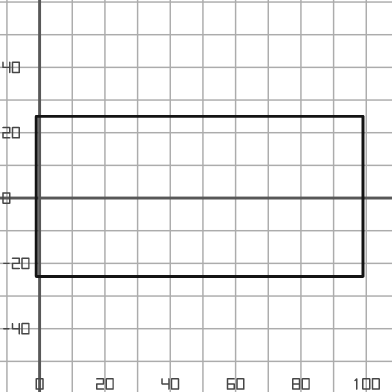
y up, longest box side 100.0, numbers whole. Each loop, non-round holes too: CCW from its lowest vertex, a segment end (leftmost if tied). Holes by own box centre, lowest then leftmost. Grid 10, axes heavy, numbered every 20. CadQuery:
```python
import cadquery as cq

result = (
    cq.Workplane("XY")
    .moveTo(-1.0, -24.0)
    .lineTo(99.0, -24.0)
    .lineTo(99.0, 25.0)
    .lineTo(-1.0, 25.0)
    .close()
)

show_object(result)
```